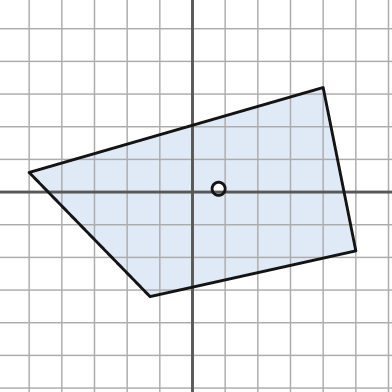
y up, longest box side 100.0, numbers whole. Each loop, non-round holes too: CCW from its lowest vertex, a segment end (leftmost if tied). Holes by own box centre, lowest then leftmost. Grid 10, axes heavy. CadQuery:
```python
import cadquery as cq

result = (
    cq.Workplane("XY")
    .moveTo(-13.0, -32.0)
    .lineTo(50.0, -18.0)
    .lineTo(40.0, 32.0)
    .lineTo(-50.0, 6.0)
    .close()
    .moveTo(8.0, 1.0)
    .circle(2.0)
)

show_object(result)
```